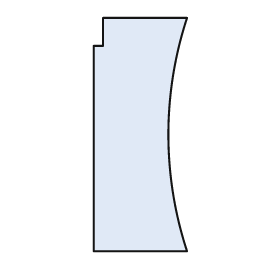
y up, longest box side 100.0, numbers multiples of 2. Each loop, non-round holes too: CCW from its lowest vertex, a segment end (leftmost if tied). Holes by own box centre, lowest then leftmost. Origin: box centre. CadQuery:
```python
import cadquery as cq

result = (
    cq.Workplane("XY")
    .moveTo(-20.0, -50.0)
    .lineTo(20.0, -50.0)
    .threePointArc((12.0, 0.0), (20.0, 50.0))
    .lineTo(-16.0, 50.0)
    .lineTo(-16.0, 38.0)
    .lineTo(-20.0, 38.0)
    .close()
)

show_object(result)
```